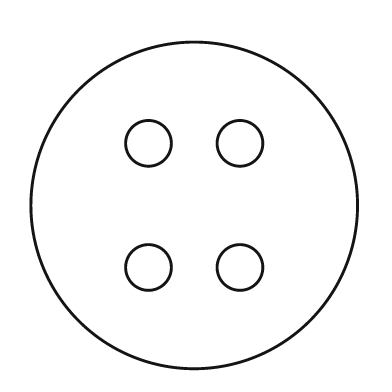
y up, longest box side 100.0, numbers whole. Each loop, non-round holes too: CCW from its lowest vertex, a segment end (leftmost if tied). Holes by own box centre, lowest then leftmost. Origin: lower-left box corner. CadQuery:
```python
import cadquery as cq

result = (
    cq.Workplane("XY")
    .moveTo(50.0, 50.0)
    .circle(50.0)
    .moveTo(36.0, 31.0)
    .circle(7.0)
    .moveTo(64.0, 31.0)
    .circle(7.0)
    .moveTo(36.0, 69.0)
    .circle(7.0)
    .moveTo(64.0, 69.0)
    .circle(7.0)
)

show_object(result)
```